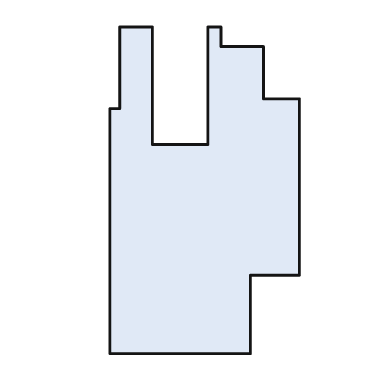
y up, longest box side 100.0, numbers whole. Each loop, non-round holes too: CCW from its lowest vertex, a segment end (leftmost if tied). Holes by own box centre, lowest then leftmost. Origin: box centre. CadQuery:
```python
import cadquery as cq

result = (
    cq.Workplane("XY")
    .moveTo(-29.0, -50.0)
    .lineTo(14.0, -50.0)
    .lineTo(14.0, -26.0)
    .lineTo(29.0, -26.0)
    .lineTo(29.0, 28.0)
    .lineTo(18.0, 28.0)
    .lineTo(18.0, 44.0)
    .lineTo(5.0, 44.0)
    .lineTo(5.0, 50.0)
    .lineTo(1.0, 50.0)
    .lineTo(1.0, 14.0)
    .lineTo(-16.0, 14.0)
    .lineTo(-16.0, 50.0)
    .lineTo(-26.0, 50.0)
    .lineTo(-26.0, 25.0)
    .lineTo(-29.0, 25.0)
    .close()
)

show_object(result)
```